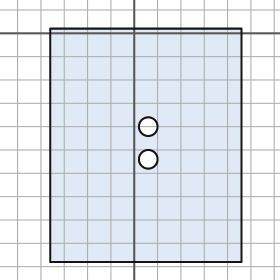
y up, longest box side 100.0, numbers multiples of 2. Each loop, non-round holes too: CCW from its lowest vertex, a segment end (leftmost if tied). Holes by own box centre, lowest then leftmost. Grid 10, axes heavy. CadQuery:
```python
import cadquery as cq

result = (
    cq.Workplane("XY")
    .moveTo(-36.0, -98.0)
    .lineTo(46.0, -98.0)
    .lineTo(46.0, 2.0)
    .lineTo(-36.0, 2.0)
    .close()
    .moveTo(6.0, -54.0)
    .circle(4.0)
    .moveTo(6.0, -40.0)
    .circle(4.0)
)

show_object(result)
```